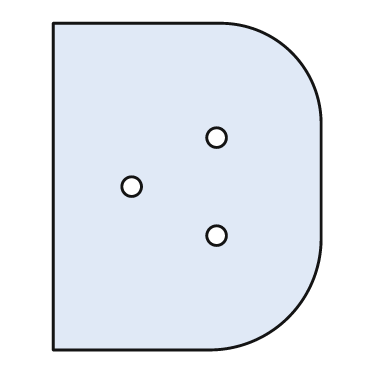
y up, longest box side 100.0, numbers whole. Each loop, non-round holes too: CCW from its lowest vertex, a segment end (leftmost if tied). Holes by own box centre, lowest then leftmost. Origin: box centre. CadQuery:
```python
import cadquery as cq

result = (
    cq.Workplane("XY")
    .moveTo(-41.0, -50.0)
    .lineTo(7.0, -50.0)
    .threePointArc((31.0, -40.0), (41.0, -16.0))
    .lineTo(41.0, 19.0)
    .threePointArc((32.0, 41.0), (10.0, 50.0))
    .lineTo(-41.0, 50.0)
    .close()
    .moveTo(9.0, -15.0)
    .circle(3.0)
    .moveTo(-17.0, 0.0)
    .circle(3.0)
    .moveTo(9.0, 15.0)
    .circle(3.0)
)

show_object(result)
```